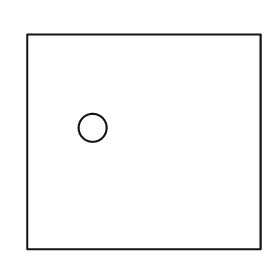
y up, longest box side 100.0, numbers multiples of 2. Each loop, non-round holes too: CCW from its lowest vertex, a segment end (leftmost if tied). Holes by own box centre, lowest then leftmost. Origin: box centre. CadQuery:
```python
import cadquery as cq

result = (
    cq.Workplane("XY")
    .moveTo(-50.0, -46.0)
    .lineTo(50.0, -46.0)
    .lineTo(50.0, 46.0)
    .lineTo(-50.0, 46.0)
    .close()
    .moveTo(-22.0, 6.0)
    .circle(6.0)
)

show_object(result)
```